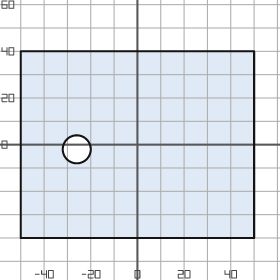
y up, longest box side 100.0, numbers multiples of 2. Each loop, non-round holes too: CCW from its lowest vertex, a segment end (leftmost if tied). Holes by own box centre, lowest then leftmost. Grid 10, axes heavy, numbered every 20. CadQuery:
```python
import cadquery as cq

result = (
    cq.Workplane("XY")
    .moveTo(-50.0, -40.0)
    .lineTo(50.0, -40.0)
    .lineTo(50.0, 40.0)
    .lineTo(-50.0, 40.0)
    .close()
    .moveTo(-26.0, -2.0)
    .circle(6.0)
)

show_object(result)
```